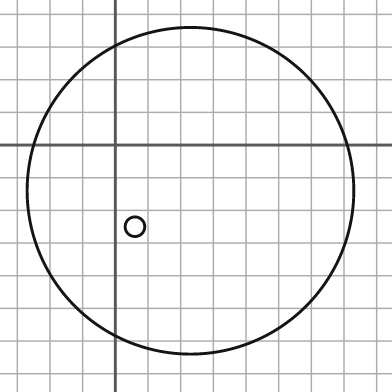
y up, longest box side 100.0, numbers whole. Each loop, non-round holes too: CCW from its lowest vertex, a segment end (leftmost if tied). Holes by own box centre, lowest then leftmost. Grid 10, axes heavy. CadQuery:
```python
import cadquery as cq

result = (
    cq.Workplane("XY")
    .moveTo(23.0, -14.0)
    .circle(50.0)
    .moveTo(6.0, -25.0)
    .circle(3.0)
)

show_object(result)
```